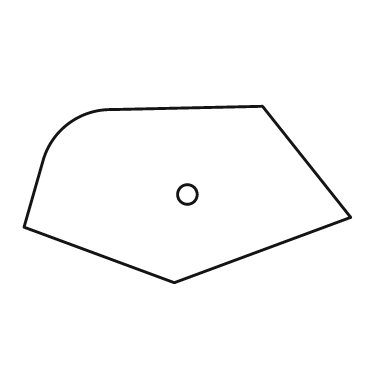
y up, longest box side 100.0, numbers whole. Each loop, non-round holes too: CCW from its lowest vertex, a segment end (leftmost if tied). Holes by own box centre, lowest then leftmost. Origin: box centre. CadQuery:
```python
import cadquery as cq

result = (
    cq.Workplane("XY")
    .moveTo(-4.0, -27.0)
    .lineTo(50.0, -7.0)
    .lineTo(23.0, 27.0)
    .lineTo(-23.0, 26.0)
    .threePointArc((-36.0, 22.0), (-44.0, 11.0))
    .lineTo(-50.0, -10.0)
    .close()
    .moveTo(0.0, 0.0)
    .circle(3.0)
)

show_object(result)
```